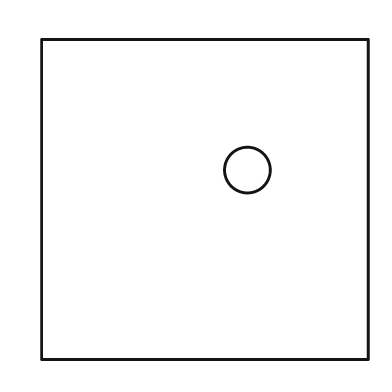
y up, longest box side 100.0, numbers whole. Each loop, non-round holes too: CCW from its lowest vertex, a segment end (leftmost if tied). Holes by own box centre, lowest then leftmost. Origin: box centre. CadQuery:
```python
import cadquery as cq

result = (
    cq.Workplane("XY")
    .moveTo(-50.0, -49.0)
    .lineTo(50.0, -49.0)
    .lineTo(50.0, 49.0)
    .lineTo(-50.0, 49.0)
    .close()
    .moveTo(13.0, 9.0)
    .circle(7.0)
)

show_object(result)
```